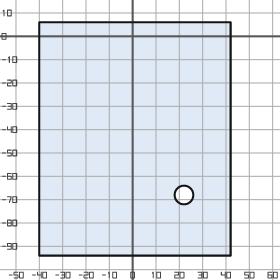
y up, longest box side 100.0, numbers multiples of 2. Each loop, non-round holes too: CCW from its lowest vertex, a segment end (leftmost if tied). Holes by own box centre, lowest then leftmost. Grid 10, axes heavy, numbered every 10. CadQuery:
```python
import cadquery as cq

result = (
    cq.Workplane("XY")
    .moveTo(-40.0, -94.0)
    .lineTo(42.0, -94.0)
    .lineTo(42.0, 6.0)
    .lineTo(-40.0, 6.0)
    .close()
    .moveTo(22.0, -68.0)
    .circle(4.0)
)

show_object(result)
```